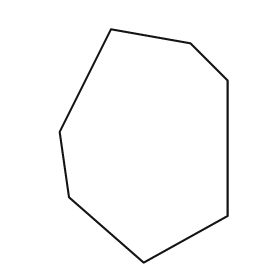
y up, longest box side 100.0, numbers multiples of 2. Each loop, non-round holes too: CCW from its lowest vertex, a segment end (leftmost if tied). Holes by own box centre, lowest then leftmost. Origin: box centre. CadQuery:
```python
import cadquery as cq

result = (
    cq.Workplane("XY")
    .moveTo(0.0, -50.0)
    .lineTo(36.0, -30.0)
    .lineTo(36.0, 28.0)
    .lineTo(20.0, 44.0)
    .lineTo(-14.0, 50.0)
    .lineTo(-36.0, 6.0)
    .lineTo(-32.0, -22.0)
    .close()
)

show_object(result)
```